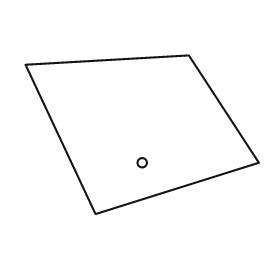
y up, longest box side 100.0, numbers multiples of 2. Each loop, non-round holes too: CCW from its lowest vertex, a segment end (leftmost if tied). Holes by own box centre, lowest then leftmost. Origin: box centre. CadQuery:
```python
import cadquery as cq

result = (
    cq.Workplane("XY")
    .moveTo(-20.0, -34.0)
    .lineTo(50.0, -12.0)
    .lineTo(20.0, 34.0)
    .lineTo(-50.0, 30.0)
    .close()
    .moveTo(0.0, -12.0)
    .circle(2.0)
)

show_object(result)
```